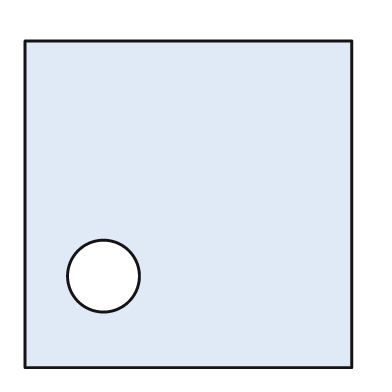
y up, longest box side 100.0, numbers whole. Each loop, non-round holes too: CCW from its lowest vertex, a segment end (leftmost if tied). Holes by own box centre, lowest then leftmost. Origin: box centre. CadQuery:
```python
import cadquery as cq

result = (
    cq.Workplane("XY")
    .moveTo(-50.0, -50.0)
    .lineTo(50.0, -50.0)
    .lineTo(50.0, 50.0)
    .lineTo(-50.0, 50.0)
    .close()
    .moveTo(-26.0, -22.0)
    .circle(11.0)
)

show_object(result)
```